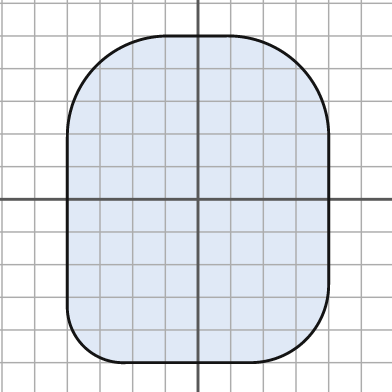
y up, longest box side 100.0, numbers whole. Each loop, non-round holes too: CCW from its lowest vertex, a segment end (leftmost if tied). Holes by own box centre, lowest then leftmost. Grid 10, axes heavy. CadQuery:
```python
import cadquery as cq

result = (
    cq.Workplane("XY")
    .moveTo(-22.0, -50.0)
    .lineTo(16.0, -50.0)
    .threePointArc((33.0, -43.0), (40.0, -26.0))
    .lineTo(40.0, 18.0)
    .threePointArc((31.0, 41.0), (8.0, 50.0))
    .lineTo(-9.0, 50.0)
    .threePointArc((-31.0, 41.0), (-40.0, 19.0))
    .lineTo(-40.0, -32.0)
    .threePointArc((-35.0, -45.0), (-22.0, -50.0))
    .close()
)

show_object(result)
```